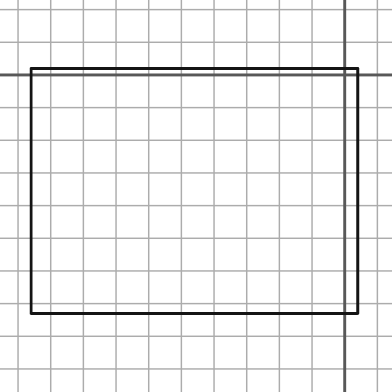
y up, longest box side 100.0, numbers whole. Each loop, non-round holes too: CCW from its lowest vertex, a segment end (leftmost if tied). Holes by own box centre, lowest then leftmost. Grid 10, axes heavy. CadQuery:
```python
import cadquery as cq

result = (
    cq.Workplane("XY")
    .moveTo(-96.0, -73.0)
    .lineTo(4.0, -73.0)
    .lineTo(4.0, 2.0)
    .lineTo(-96.0, 2.0)
    .close()
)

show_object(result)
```